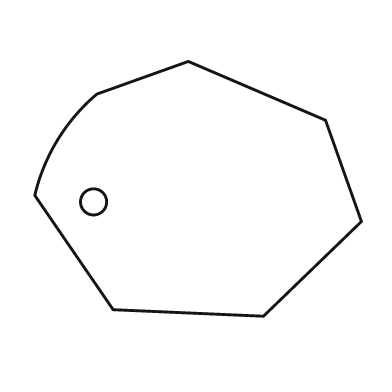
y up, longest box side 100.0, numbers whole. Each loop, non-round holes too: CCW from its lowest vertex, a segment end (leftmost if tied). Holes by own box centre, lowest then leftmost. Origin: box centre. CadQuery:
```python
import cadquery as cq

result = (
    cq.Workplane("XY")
    .moveTo(20.0, -39.0)
    .lineTo(50.0, -10.0)
    .lineTo(39.0, 21.0)
    .lineTo(-3.0, 39.0)
    .lineTo(-31.0, 29.0)
    .threePointArc((-43.0, 15.0), (-50.0, -2.0))
    .lineTo(-26.0, -37.0)
    .close()
    .moveTo(-32.0, -4.0)
    .circle(4.0)
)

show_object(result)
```